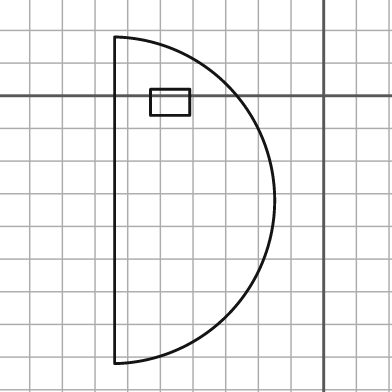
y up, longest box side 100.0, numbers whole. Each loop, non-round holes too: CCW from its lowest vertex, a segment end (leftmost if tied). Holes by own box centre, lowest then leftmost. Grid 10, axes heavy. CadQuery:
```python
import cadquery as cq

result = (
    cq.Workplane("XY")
    .moveTo(-64.0, -82.0)
    .threePointArc((-15.0, -32.0), (-64.0, 18.0))
    .close()
    .moveTo(-53.0, -6.0)
    .lineTo(-41.0, -6.0)
    .lineTo(-41.0, 2.0)
    .lineTo(-53.0, 2.0)
    .close()
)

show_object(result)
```